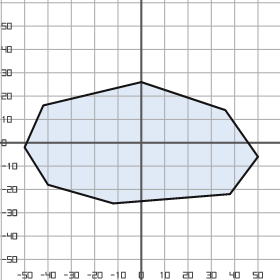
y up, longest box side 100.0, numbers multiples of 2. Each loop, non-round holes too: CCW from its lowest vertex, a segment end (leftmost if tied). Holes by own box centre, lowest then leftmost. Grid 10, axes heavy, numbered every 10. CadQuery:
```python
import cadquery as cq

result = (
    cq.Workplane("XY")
    .moveTo(-12.0, -26.0)
    .lineTo(38.0, -22.0)
    .lineTo(50.0, -6.0)
    .lineTo(36.0, 14.0)
    .lineTo(0.0, 26.0)
    .lineTo(-42.0, 16.0)
    .lineTo(-50.0, -2.0)
    .lineTo(-40.0, -18.0)
    .close()
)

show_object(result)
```